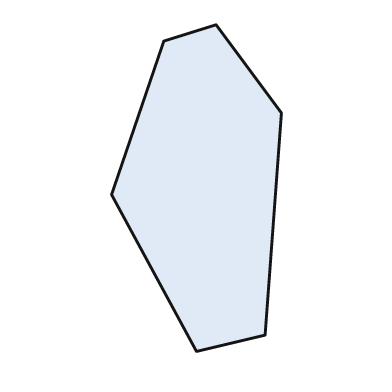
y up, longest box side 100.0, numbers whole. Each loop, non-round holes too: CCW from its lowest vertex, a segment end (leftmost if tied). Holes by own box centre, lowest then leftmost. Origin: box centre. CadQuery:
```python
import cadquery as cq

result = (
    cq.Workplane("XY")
    .moveTo(0.0, -50.0)
    .lineTo(21.0, -45.0)
    .lineTo(26.0, 23.0)
    .lineTo(6.0, 50.0)
    .lineTo(-10.0, 45.0)
    .lineTo(-26.0, -2.0)
    .close()
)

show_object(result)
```